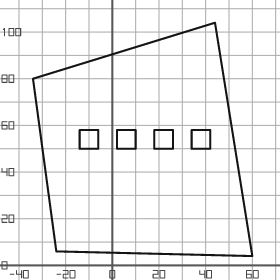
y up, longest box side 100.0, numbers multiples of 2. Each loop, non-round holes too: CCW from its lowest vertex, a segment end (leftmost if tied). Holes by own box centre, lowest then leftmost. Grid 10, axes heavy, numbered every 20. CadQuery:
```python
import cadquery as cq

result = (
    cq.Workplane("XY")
    .moveTo(60.0, 4.0)
    .lineTo(44.0, 104.0)
    .lineTo(-34.0, 80.0)
    .lineTo(-24.0, 6.0)
    .close()
    .moveTo(-14.0, 50.0)
    .lineTo(-6.0, 50.0)
    .lineTo(-6.0, 58.0)
    .lineTo(-14.0, 58.0)
    .close()
    .moveTo(2.0, 50.0)
    .lineTo(10.0, 50.0)
    .lineTo(10.0, 58.0)
    .lineTo(2.0, 58.0)
    .close()
    .moveTo(18.0, 50.0)
    .lineTo(26.0, 50.0)
    .lineTo(26.0, 58.0)
    .lineTo(18.0, 58.0)
    .close()
    .moveTo(34.0, 50.0)
    .lineTo(42.0, 50.0)
    .lineTo(42.0, 58.0)
    .lineTo(34.0, 58.0)
    .close()
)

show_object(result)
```